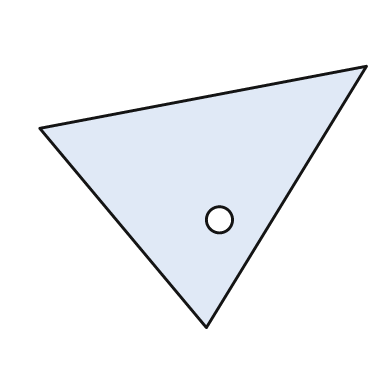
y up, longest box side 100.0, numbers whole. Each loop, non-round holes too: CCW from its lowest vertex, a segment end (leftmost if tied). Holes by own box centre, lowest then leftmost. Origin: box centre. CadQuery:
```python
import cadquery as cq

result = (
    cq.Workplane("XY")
    .moveTo(1.0, -40.0)
    .lineTo(50.0, 40.0)
    .lineTo(-50.0, 21.0)
    .close()
    .moveTo(5.0, -7.0)
    .circle(4.0)
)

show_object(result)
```